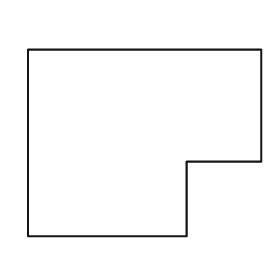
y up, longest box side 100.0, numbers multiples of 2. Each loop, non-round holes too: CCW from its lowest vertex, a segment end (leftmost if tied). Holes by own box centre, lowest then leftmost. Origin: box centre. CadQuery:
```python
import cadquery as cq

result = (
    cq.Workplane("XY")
    .moveTo(-50.0, -40.0)
    .lineTo(18.0, -40.0)
    .lineTo(18.0, -8.0)
    .lineTo(50.0, -8.0)
    .lineTo(50.0, 40.0)
    .lineTo(-50.0, 40.0)
    .close()
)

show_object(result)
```